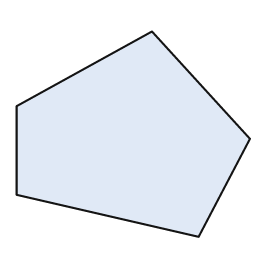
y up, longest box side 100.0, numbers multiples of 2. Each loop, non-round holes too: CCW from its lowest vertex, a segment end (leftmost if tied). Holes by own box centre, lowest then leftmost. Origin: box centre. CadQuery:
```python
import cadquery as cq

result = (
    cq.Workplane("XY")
    .moveTo(28.0, -44.0)
    .lineTo(50.0, -2.0)
    .lineTo(8.0, 44.0)
    .lineTo(-50.0, 12.0)
    .lineTo(-50.0, -26.0)
    .close()
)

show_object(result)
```